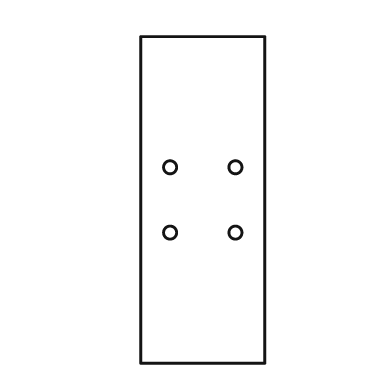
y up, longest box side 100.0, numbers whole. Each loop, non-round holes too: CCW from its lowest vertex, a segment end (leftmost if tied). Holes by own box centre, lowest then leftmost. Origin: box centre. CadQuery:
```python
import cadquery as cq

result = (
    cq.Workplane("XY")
    .moveTo(-19.0, -50.0)
    .lineTo(19.0, -50.0)
    .lineTo(19.0, 50.0)
    .lineTo(-19.0, 50.0)
    .close()
    .moveTo(-10.0, -10.0)
    .circle(2.0)
    .moveTo(10.0, -10.0)
    .circle(2.0)
    .moveTo(-10.0, 10.0)
    .circle(2.0)
    .moveTo(10.0, 10.0)
    .circle(2.0)
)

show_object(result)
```